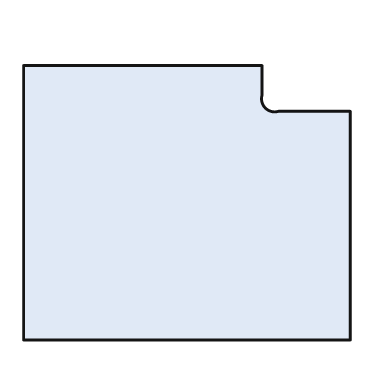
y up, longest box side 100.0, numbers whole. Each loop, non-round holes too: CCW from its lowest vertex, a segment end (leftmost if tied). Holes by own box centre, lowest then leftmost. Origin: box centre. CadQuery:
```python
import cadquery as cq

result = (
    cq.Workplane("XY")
    .moveTo(-50.0, -42.0)
    .lineTo(50.0, -42.0)
    .lineTo(50.0, 28.0)
    .lineTo(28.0, 28.0)
    .threePointArc((24.0, 29.0), (23.0, 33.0))
    .lineTo(23.0, 42.0)
    .lineTo(-50.0, 42.0)
    .close()
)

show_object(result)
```